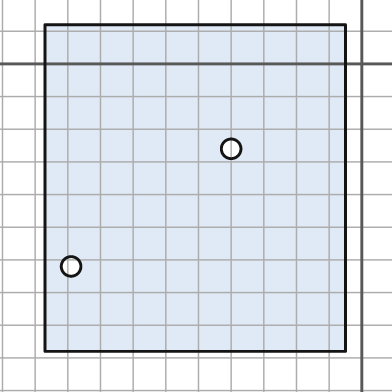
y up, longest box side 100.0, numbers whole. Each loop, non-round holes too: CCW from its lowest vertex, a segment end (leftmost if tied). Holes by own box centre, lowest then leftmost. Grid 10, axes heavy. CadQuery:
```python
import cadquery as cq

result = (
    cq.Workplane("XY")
    .moveTo(-97.0, -88.0)
    .lineTo(-5.0, -88.0)
    .lineTo(-5.0, 12.0)
    .lineTo(-97.0, 12.0)
    .close()
    .moveTo(-89.0, -62.0)
    .circle(3.0)
    .moveTo(-40.0, -26.0)
    .circle(3.0)
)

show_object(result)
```